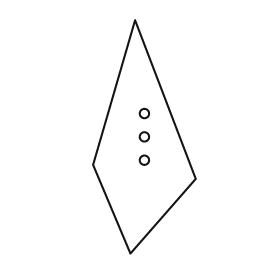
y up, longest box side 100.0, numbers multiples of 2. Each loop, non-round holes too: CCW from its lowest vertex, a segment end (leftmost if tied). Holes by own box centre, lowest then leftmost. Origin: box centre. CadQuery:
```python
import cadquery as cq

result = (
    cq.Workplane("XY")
    .moveTo(-6.0, -50.0)
    .lineTo(22.0, -18.0)
    .lineTo(-4.0, 50.0)
    .lineTo(-22.0, -12.0)
    .close()
    .moveTo(0.0, -10.0)
    .circle(2.0)
    .moveTo(0.0, 0.0)
    .circle(2.0)
    .moveTo(0.0, 10.0)
    .circle(2.0)
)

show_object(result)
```